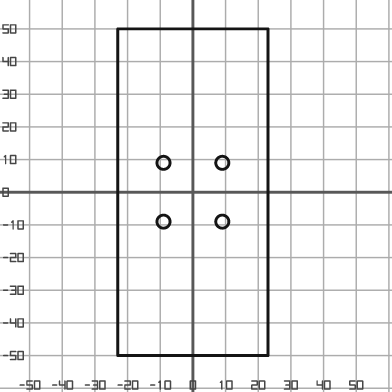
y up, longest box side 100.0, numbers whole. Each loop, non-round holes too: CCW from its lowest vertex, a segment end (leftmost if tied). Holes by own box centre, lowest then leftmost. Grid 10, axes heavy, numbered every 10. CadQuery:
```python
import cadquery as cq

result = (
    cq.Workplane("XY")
    .moveTo(-23.0, -50.0)
    .lineTo(23.0, -50.0)
    .lineTo(23.0, 50.0)
    .lineTo(-23.0, 50.0)
    .close()
    .moveTo(-9.0, -9.0)
    .circle(2.0)
    .moveTo(9.0, -9.0)
    .circle(2.0)
    .moveTo(-9.0, 9.0)
    .circle(2.0)
    .moveTo(9.0, 9.0)
    .circle(2.0)
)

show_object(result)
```